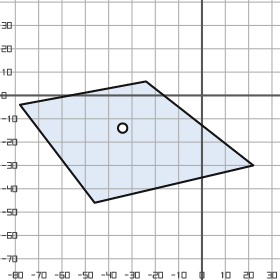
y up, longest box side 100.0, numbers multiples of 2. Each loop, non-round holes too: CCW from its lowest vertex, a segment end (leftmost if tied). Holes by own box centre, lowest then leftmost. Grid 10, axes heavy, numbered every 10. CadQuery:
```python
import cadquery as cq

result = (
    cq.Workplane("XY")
    .moveTo(-46.0, -46.0)
    .lineTo(22.0, -30.0)
    .lineTo(-24.0, 6.0)
    .lineTo(-78.0, -4.0)
    .close()
    .moveTo(-34.0, -14.0)
    .circle(2.0)
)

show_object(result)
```